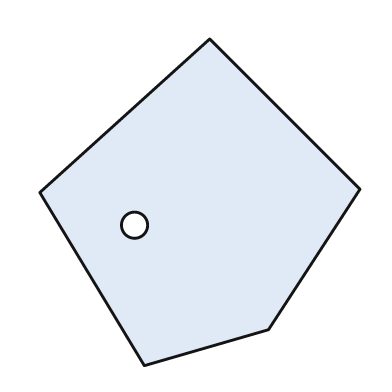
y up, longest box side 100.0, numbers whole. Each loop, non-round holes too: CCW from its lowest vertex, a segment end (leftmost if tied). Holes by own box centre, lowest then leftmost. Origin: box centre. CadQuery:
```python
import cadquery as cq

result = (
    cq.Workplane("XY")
    .moveTo(-17.0, -50.0)
    .lineTo(21.0, -39.0)
    .lineTo(49.0, 4.0)
    .lineTo(3.0, 50.0)
    .lineTo(-49.0, 3.0)
    .close()
    .moveTo(-20.0, -7.0)
    .circle(4.0)
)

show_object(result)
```